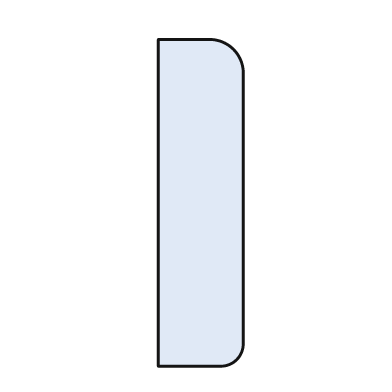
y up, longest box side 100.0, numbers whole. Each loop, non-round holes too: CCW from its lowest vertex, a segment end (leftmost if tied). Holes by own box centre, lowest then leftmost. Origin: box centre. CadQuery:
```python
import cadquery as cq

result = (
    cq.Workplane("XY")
    .moveTo(-13.0, -50.0)
    .lineTo(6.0, -50.0)
    .threePointArc((11.0, -48.0), (13.0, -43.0))
    .lineTo(13.0, 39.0)
    .threePointArc((10.0, 47.0), (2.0, 50.0))
    .lineTo(-13.0, 50.0)
    .close()
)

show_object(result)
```